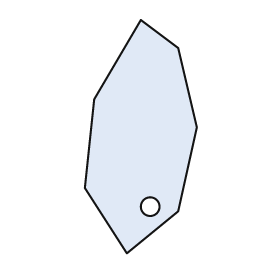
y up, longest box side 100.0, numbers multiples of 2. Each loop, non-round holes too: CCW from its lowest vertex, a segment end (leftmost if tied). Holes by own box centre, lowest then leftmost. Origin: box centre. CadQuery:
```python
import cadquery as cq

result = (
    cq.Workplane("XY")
    .moveTo(-6.0, -50.0)
    .lineTo(16.0, -32.0)
    .lineTo(24.0, 4.0)
    .lineTo(16.0, 38.0)
    .lineTo(0.0, 50.0)
    .lineTo(-20.0, 16.0)
    .lineTo(-24.0, -22.0)
    .close()
    .moveTo(4.0, -30.0)
    .circle(4.0)
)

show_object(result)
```